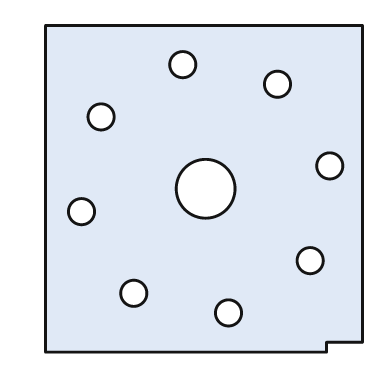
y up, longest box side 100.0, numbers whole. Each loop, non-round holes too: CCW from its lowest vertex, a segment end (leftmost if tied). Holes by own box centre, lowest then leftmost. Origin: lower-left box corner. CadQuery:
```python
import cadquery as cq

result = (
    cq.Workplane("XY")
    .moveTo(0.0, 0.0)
    .lineTo(86.0, 0.0)
    .lineTo(86.0, 3.0)
    .lineTo(97.0, 3.0)
    .lineTo(97.0, 100.0)
    .lineTo(0.0, 100.0)
    .close()
    .moveTo(56.0, 12.0)
    .circle(4.0)
    .moveTo(27.0, 18.0)
    .circle(4.0)
    .moveTo(81.0, 28.0)
    .circle(4.0)
    .moveTo(11.0, 43.0)
    .circle(4.0)
    .moveTo(49.0, 50.0)
    .circle(9.0)
    .moveTo(87.0, 57.0)
    .circle(4.0)
    .moveTo(17.0, 72.0)
    .circle(4.0)
    .moveTo(71.0, 82.0)
    .circle(4.0)
    .moveTo(42.0, 88.0)
    .circle(4.0)
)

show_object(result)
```